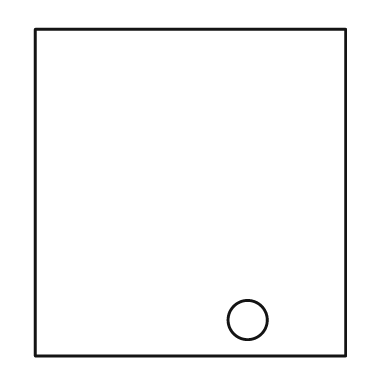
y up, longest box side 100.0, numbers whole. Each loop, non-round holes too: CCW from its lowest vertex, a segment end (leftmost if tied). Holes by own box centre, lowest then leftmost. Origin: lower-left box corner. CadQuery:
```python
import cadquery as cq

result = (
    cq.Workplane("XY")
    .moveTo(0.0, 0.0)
    .lineTo(95.0, 0.0)
    .lineTo(95.0, 100.0)
    .lineTo(0.0, 100.0)
    .close()
    .moveTo(65.0, 11.0)
    .circle(6.0)
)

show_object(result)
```